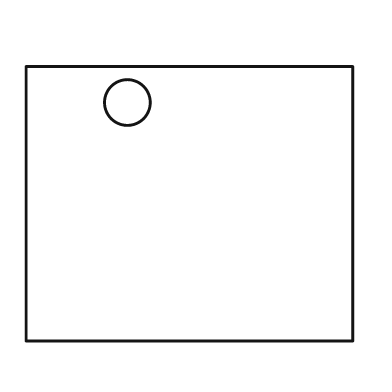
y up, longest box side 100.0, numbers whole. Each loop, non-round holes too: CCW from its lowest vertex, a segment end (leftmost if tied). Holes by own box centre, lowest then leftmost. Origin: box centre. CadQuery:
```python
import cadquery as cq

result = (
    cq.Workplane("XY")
    .moveTo(-50.0, -42.0)
    .lineTo(50.0, -42.0)
    .lineTo(50.0, 42.0)
    .lineTo(-50.0, 42.0)
    .close()
    .moveTo(-19.0, 31.0)
    .circle(7.0)
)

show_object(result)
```